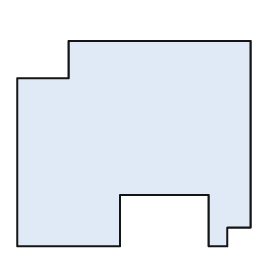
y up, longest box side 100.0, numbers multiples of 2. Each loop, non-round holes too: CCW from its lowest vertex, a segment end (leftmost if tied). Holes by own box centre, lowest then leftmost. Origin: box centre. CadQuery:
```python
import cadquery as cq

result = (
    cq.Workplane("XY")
    .moveTo(-50.0, -44.0)
    .lineTo(-6.0, -44.0)
    .lineTo(-6.0, -22.0)
    .lineTo(32.0, -22.0)
    .lineTo(32.0, -44.0)
    .lineTo(40.0, -44.0)
    .lineTo(40.0, -36.0)
    .lineTo(50.0, -36.0)
    .lineTo(50.0, 44.0)
    .lineTo(-28.0, 44.0)
    .lineTo(-28.0, 28.0)
    .lineTo(-50.0, 28.0)
    .close()
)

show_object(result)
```